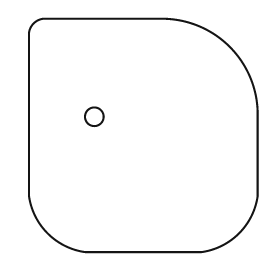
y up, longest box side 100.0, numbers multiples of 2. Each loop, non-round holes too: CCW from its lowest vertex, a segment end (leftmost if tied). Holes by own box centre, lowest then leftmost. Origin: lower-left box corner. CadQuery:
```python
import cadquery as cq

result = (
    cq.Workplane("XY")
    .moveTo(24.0, 0.0)
    .lineTo(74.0, 0.0)
    .threePointArc((90.0, 8.0), (98.0, 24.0))
    .lineTo(98.0, 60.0)
    .threePointArc((86.0, 88.0), (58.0, 100.0))
    .lineTo(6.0, 100.0)
    .threePointArc((2.0, 98.0), (0.0, 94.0))
    .lineTo(0.0, 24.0)
    .threePointArc((8.0, 8.0), (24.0, 0.0))
    .close()
    .moveTo(28.0, 58.0)
    .circle(4.0)
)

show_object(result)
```